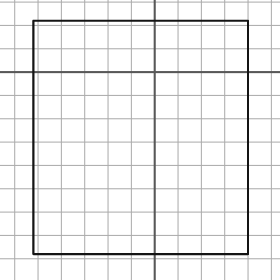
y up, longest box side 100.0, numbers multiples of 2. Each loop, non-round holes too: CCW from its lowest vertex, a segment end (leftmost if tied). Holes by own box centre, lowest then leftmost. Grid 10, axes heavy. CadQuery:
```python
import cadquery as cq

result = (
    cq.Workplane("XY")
    .moveTo(-52.0, -78.0)
    .lineTo(40.0, -78.0)
    .lineTo(40.0, 22.0)
    .lineTo(-52.0, 22.0)
    .close()
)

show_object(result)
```